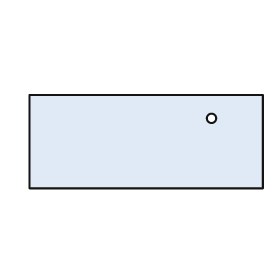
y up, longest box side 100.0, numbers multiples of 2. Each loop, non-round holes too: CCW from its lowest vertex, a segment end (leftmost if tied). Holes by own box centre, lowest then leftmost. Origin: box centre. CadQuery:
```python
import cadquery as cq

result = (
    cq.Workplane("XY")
    .moveTo(-50.0, -20.0)
    .lineTo(50.0, -20.0)
    .lineTo(50.0, 20.0)
    .lineTo(-50.0, 20.0)
    .close()
    .moveTo(28.0, 10.0)
    .circle(2.0)
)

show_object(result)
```